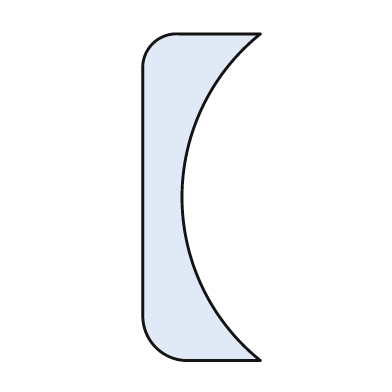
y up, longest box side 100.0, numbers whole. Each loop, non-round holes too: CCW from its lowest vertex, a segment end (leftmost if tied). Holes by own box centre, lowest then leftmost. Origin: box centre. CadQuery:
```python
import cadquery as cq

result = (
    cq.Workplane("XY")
    .moveTo(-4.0, -50.0)
    .lineTo(18.0, -50.0)
    .threePointArc((-6.0, 0.0), (18.0, 50.0))
    .lineTo(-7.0, 50.0)
    .threePointArc((-15.0, 47.0), (-18.0, 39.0))
    .lineTo(-18.0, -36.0)
    .threePointArc((-14.0, -46.0), (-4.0, -50.0))
    .close()
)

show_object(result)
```